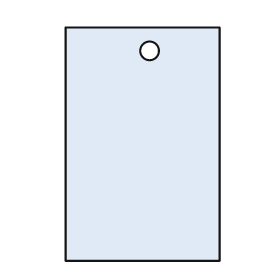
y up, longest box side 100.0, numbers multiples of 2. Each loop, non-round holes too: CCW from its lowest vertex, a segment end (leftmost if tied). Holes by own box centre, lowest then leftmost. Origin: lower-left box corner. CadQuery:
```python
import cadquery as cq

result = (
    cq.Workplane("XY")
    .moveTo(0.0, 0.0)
    .lineTo(66.0, 0.0)
    .lineTo(66.0, 100.0)
    .lineTo(0.0, 100.0)
    .close()
    .moveTo(36.0, 90.0)
    .circle(4.0)
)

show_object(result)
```